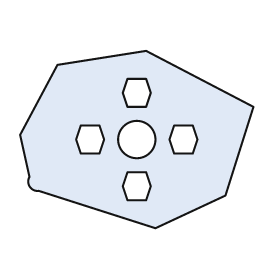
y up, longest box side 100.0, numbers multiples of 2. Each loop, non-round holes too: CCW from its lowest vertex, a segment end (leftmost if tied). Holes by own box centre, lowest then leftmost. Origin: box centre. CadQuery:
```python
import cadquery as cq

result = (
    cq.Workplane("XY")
    .moveTo(8.0, -38.0)
    .lineTo(38.0, -24.0)
    .lineTo(50.0, 14.0)
    .lineTo(4.0, 38.0)
    .lineTo(-34.0, 32.0)
    .lineTo(-50.0, 2.0)
    .lineTo(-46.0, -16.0)
    .threePointArc((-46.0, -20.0), (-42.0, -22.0))
    .close()
    .moveTo(-4.0, -26.0)
    .lineTo(4.0, -26.0)
    .lineTo(6.0, -20.0)
    .lineTo(4.0, -14.0)
    .lineTo(-4.0, -14.0)
    .lineTo(-6.0, -20.0)
    .close()
    .moveTo(-24.0, -6.0)
    .lineTo(-16.0, -6.0)
    .lineTo(-14.0, 0.0)
    .lineTo(-16.0, 6.0)
    .lineTo(-24.0, 6.0)
    .lineTo(-26.0, 0.0)
    .close()
    .moveTo(0.0, 0.0)
    .circle(8.0)
    .moveTo(16.0, -6.0)
    .lineTo(24.0, -6.0)
    .lineTo(26.0, 0.0)
    .lineTo(24.0, 6.0)
    .lineTo(16.0, 6.0)
    .lineTo(14.0, 0.0)
    .close()
    .moveTo(-4.0, 14.0)
    .lineTo(4.0, 14.0)
    .lineTo(6.0, 20.0)
    .lineTo(4.0, 26.0)
    .lineTo(-4.0, 26.0)
    .lineTo(-6.0, 20.0)
    .close()
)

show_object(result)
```